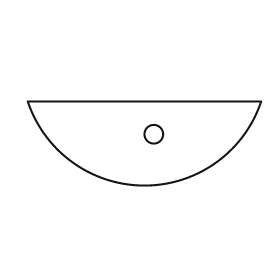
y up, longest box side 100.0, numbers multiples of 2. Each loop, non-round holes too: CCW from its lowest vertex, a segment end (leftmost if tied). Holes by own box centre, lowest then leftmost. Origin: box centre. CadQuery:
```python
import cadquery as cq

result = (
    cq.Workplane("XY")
    .moveTo(-50.0, 18.0)
    .threePointArc((0.0, -18.0), (50.0, 18.0))
    .close()
    .moveTo(4.0, 4.0)
    .circle(4.0)
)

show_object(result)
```